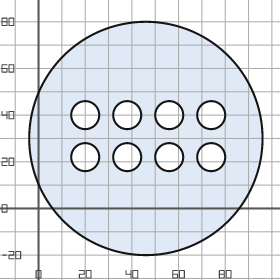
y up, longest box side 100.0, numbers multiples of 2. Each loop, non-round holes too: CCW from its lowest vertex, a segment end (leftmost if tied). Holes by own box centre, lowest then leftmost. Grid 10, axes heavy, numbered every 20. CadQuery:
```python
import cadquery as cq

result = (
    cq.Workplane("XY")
    .moveTo(46.0, 30.0)
    .circle(50.0)
    .moveTo(20.0, 22.0)
    .circle(6.0)
    .moveTo(38.0, 22.0)
    .circle(6.0)
    .moveTo(56.0, 22.0)
    .circle(6.0)
    .moveTo(74.0, 22.0)
    .circle(6.0)
    .moveTo(20.0, 40.0)
    .circle(6.0)
    .moveTo(38.0, 40.0)
    .circle(6.0)
    .moveTo(56.0, 40.0)
    .circle(6.0)
    .moveTo(74.0, 40.0)
    .circle(6.0)
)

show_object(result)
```